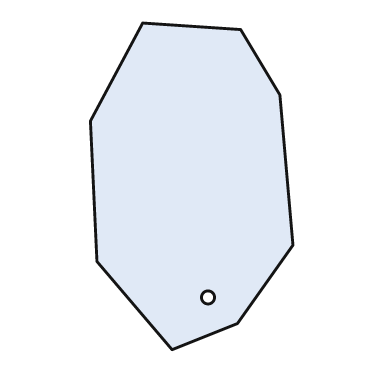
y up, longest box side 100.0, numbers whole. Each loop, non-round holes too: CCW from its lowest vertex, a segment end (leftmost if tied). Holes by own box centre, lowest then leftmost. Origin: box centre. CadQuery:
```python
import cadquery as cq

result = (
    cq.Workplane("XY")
    .moveTo(-6.0, -50.0)
    .lineTo(14.0, -42.0)
    .lineTo(31.0, -18.0)
    .lineTo(27.0, 28.0)
    .lineTo(15.0, 48.0)
    .lineTo(-15.0, 50.0)
    .lineTo(-31.0, 20.0)
    .lineTo(-29.0, -23.0)
    .close()
    .moveTo(5.0, -34.0)
    .circle(2.0)
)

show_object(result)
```